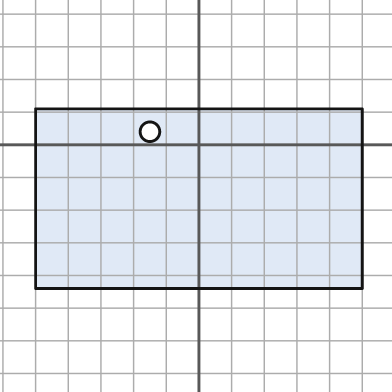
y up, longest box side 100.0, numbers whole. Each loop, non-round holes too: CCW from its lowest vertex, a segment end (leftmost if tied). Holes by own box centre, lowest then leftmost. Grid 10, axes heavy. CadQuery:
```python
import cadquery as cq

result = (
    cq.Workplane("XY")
    .moveTo(-50.0, -44.0)
    .lineTo(50.0, -44.0)
    .lineTo(50.0, 11.0)
    .lineTo(-50.0, 11.0)
    .close()
    .moveTo(-15.0, 4.0)
    .circle(3.0)
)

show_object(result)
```